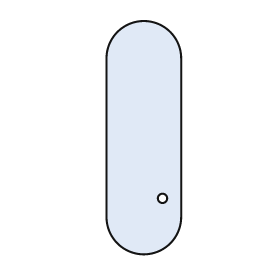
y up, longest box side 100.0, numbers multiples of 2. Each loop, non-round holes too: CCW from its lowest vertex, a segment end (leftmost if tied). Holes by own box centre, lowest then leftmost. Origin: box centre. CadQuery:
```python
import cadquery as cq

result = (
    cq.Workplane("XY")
    .moveTo(-16.0, -34.0)
    .threePointArc((0.0, -50.0), (16.0, -34.0))
    .lineTo(16.0, 34.0)
    .threePointArc((0.0, 50.0), (-16.0, 34.0))
    .close()
    .moveTo(8.0, -26.0)
    .circle(2.0)
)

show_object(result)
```